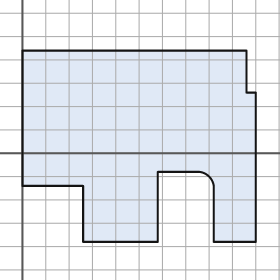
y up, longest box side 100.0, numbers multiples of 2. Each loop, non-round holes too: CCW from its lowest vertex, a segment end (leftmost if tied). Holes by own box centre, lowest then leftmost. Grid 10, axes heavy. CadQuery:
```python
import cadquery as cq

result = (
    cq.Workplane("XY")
    .moveTo(26.0, -38.0)
    .lineTo(58.0, -38.0)
    .lineTo(58.0, -8.0)
    .lineTo(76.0, -8.0)
    .threePointArc((80.0, -10.0), (82.0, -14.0))
    .lineTo(82.0, -38.0)
    .lineTo(100.0, -38.0)
    .lineTo(100.0, 26.0)
    .lineTo(96.0, 26.0)
    .lineTo(96.0, 44.0)
    .lineTo(0.0, 44.0)
    .lineTo(0.0, -14.0)
    .lineTo(26.0, -14.0)
    .close()
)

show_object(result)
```